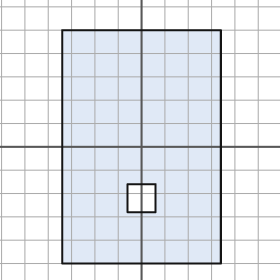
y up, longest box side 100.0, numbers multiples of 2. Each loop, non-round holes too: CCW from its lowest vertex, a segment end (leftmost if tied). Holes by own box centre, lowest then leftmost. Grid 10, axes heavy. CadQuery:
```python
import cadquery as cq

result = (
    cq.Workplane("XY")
    .moveTo(-34.0, -50.0)
    .lineTo(34.0, -50.0)
    .lineTo(34.0, 50.0)
    .lineTo(-34.0, 50.0)
    .close()
    .moveTo(-6.0, -28.0)
    .lineTo(6.0, -28.0)
    .lineTo(6.0, -16.0)
    .lineTo(-6.0, -16.0)
    .close()
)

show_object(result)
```